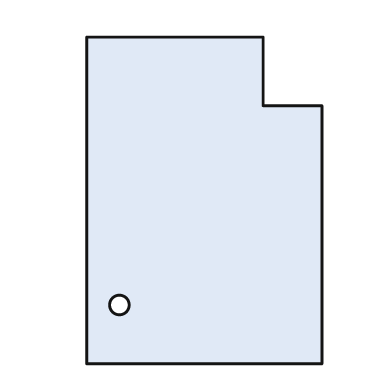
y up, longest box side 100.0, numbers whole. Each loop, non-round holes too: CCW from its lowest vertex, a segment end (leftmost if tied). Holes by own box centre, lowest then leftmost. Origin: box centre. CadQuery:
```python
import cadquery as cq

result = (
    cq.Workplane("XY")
    .moveTo(-36.0, -50.0)
    .lineTo(36.0, -50.0)
    .lineTo(36.0, 29.0)
    .lineTo(18.0, 29.0)
    .lineTo(18.0, 50.0)
    .lineTo(-36.0, 50.0)
    .close()
    .moveTo(-26.0, -32.0)
    .circle(3.0)
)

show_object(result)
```